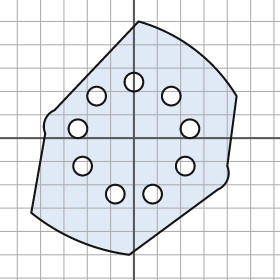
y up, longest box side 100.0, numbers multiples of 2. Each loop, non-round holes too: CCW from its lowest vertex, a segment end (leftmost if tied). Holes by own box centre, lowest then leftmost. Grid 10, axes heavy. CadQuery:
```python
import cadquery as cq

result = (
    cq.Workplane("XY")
    .moveTo(-2.0, -50.0)
    .lineTo(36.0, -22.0)
    .threePointArc((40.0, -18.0), (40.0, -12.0))
    .lineTo(44.0, 18.0)
    .threePointArc((26.0, 38.0), (2.0, 50.0))
    .lineTo(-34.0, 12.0)
    .threePointArc((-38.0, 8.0), (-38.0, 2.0))
    .lineTo(-44.0, -32.0)
    .threePointArc((-24.0, -44.0), (-2.0, -50.0))
    .close()
    .moveTo(-8.0, -24.0)
    .circle(4.0)
    .moveTo(8.0, -24.0)
    .circle(4.0)
    .moveTo(-22.0, -12.0)
    .circle(4.0)
    .moveTo(22.0, -12.0)
    .circle(4.0)
    .moveTo(-24.0, 4.0)
    .circle(4.0)
    .moveTo(24.0, 4.0)
    .circle(4.0)
    .moveTo(-16.0, 18.0)
    .circle(4.0)
    .moveTo(16.0, 18.0)
    .circle(4.0)
    .moveTo(0.0, 24.0)
    .circle(4.0)
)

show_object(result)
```